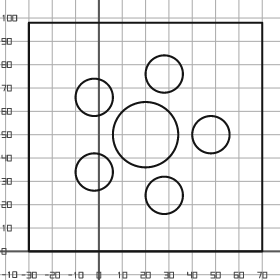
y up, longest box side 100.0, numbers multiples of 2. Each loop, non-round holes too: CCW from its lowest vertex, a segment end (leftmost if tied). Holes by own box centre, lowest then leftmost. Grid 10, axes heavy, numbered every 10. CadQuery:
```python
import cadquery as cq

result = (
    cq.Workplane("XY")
    .moveTo(-30.0, 0.0)
    .lineTo(70.0, 0.0)
    .lineTo(70.0, 98.0)
    .lineTo(-30.0, 98.0)
    .close()
    .moveTo(28.0, 24.0)
    .circle(8.0)
    .moveTo(-2.0, 34.0)
    .circle(8.0)
    .moveTo(20.0, 50.0)
    .circle(14.0)
    .moveTo(48.0, 50.0)
    .circle(8.0)
    .moveTo(-2.0, 66.0)
    .circle(8.0)
    .moveTo(28.0, 76.0)
    .circle(8.0)
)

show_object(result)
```